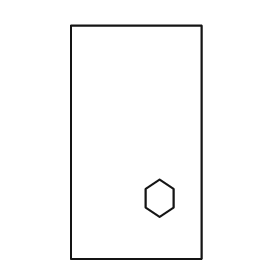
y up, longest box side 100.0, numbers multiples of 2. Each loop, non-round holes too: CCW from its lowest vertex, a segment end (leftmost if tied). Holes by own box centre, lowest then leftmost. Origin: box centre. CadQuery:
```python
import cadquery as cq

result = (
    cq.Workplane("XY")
    .moveTo(-28.0, -50.0)
    .lineTo(28.0, -50.0)
    .lineTo(28.0, 50.0)
    .lineTo(-28.0, 50.0)
    .close()
    .moveTo(10.0, -32.0)
    .lineTo(16.0, -28.0)
    .lineTo(16.0, -20.0)
    .lineTo(10.0, -16.0)
    .lineTo(4.0, -20.0)
    .lineTo(4.0, -28.0)
    .close()
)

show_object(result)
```